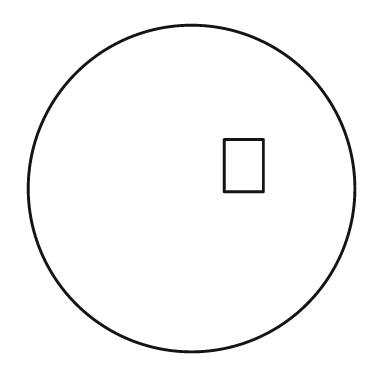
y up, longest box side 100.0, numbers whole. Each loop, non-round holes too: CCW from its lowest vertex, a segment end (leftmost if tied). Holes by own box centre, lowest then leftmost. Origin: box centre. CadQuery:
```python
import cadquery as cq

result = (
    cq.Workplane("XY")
    .moveTo(0.0, 0.0)
    .circle(50.0)
    .moveTo(10.0, -1.0)
    .lineTo(22.0, -1.0)
    .lineTo(22.0, 15.0)
    .lineTo(10.0, 15.0)
    .close()
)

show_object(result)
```